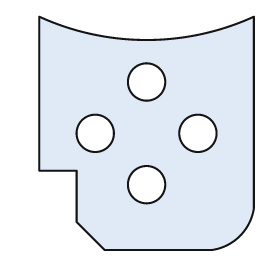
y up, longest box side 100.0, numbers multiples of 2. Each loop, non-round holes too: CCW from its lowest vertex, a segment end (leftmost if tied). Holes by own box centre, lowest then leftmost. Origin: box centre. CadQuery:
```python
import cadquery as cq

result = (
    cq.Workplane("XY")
    .moveTo(-18.0, -50.0)
    .lineTo(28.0, -50.0)
    .threePointArc((40.0, -44.0), (46.0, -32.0))
    .lineTo(46.0, 50.0)
    .threePointArc((0.0, 40.0), (-46.0, 50.0))
    .lineTo(-46.0, -16.0)
    .lineTo(-30.0, -16.0)
    .lineTo(-30.0, -38.0)
    .close()
    .moveTo(0.0, -22.0)
    .circle(8.0)
    .moveTo(-22.0, 0.0)
    .circle(8.0)
    .moveTo(22.0, 0.0)
    .circle(8.0)
    .moveTo(0.0, 22.0)
    .circle(8.0)
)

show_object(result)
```